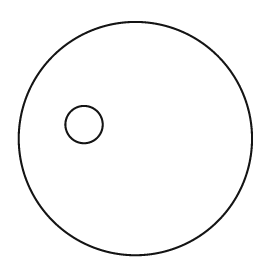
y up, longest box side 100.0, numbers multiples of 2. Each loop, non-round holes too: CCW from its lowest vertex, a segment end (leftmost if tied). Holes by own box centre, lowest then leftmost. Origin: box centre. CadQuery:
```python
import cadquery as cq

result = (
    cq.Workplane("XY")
    .moveTo(0.0, 0.0)
    .circle(50.0)
    .moveTo(-22.0, 6.0)
    .circle(8.0)
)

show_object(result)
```